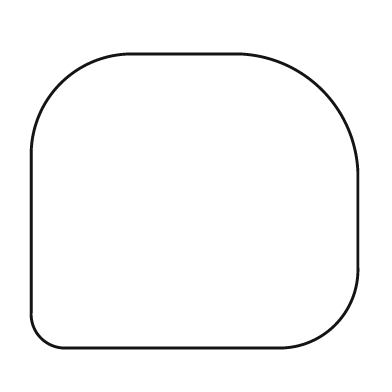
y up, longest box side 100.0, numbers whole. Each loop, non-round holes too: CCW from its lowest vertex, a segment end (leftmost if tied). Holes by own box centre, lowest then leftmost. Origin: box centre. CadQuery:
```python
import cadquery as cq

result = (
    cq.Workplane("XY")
    .moveTo(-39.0, -45.0)
    .lineTo(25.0, -45.0)
    .threePointArc((43.0, -38.0), (50.0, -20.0))
    .lineTo(50.0, 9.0)
    .threePointArc((39.0, 34.0), (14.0, 45.0))
    .lineTo(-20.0, 45.0)
    .threePointArc((-41.0, 36.0), (-50.0, 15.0))
    .lineTo(-50.0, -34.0)
    .threePointArc((-47.0, -42.0), (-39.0, -45.0))
    .close()
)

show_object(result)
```